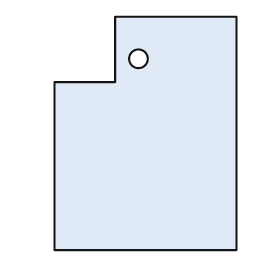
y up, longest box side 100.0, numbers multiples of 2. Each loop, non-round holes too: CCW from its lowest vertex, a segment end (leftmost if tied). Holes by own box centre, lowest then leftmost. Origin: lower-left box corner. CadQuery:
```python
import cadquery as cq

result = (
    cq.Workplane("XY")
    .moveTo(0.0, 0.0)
    .lineTo(78.0, 0.0)
    .lineTo(78.0, 100.0)
    .lineTo(26.0, 100.0)
    .lineTo(26.0, 72.0)
    .lineTo(0.0, 72.0)
    .close()
    .moveTo(36.0, 82.0)
    .circle(4.0)
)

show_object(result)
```